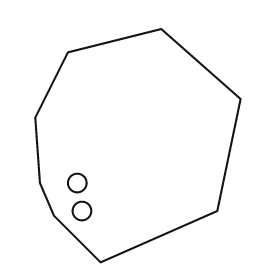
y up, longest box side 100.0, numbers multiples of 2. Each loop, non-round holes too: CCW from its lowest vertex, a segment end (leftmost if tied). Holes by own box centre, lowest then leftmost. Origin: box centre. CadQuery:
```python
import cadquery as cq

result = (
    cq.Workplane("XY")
    .moveTo(-16.0, -50.0)
    .lineTo(34.0, -28.0)
    .lineTo(44.0, 20.0)
    .lineTo(10.0, 50.0)
    .lineTo(-30.0, 40.0)
    .lineTo(-44.0, 12.0)
    .lineTo(-42.0, -16.0)
    .lineTo(-36.0, -30.0)
    .close()
    .moveTo(-24.0, -28.0)
    .circle(4.0)
    .moveTo(-26.0, -16.0)
    .circle(4.0)
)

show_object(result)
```